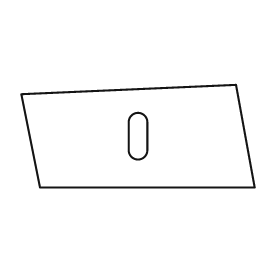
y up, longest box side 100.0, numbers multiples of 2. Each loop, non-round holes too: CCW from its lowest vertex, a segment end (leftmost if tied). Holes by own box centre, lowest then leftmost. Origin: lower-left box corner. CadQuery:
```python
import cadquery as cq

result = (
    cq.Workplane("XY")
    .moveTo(8.0, 0.0)
    .lineTo(100.0, 0.0)
    .lineTo(92.0, 44.0)
    .lineTo(0.0, 40.0)
    .close()
    .moveTo(46.0, 16.0)
    .threePointArc((50.0, 12.0), (54.0, 16.0))
    .lineTo(54.0, 28.0)
    .threePointArc((50.0, 32.0), (46.0, 28.0))
    .close()
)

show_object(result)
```